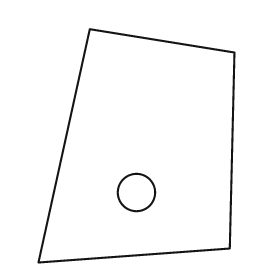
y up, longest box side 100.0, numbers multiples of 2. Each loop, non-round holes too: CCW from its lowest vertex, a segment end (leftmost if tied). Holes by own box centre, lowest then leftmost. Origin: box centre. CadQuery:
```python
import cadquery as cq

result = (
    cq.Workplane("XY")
    .moveTo(-42.0, -50.0)
    .lineTo(40.0, -44.0)
    .lineTo(42.0, 40.0)
    .lineTo(-20.0, 50.0)
    .close()
    .moveTo(0.0, -20.0)
    .circle(8.0)
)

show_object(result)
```